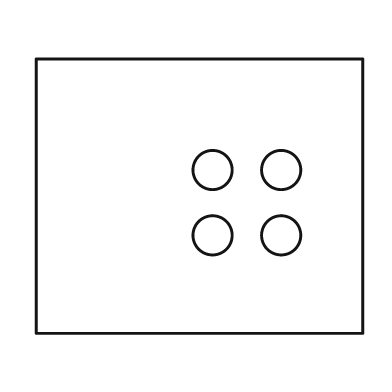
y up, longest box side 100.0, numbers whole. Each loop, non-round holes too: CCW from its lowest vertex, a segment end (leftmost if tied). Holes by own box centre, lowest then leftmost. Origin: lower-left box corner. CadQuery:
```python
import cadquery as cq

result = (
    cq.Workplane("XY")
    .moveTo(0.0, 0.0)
    .lineTo(100.0, 0.0)
    .lineTo(100.0, 84.0)
    .lineTo(0.0, 84.0)
    .close()
    .moveTo(54.0, 30.0)
    .circle(6.0)
    .moveTo(75.0, 30.0)
    .circle(6.0)
    .moveTo(54.0, 50.0)
    .circle(6.0)
    .moveTo(75.0, 50.0)
    .circle(6.0)
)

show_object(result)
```